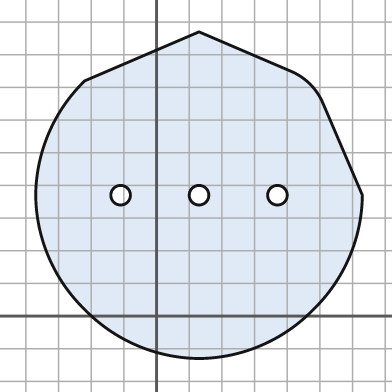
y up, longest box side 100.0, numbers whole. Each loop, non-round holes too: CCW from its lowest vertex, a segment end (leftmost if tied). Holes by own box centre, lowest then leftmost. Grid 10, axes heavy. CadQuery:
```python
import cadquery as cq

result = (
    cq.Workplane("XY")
    .moveTo(13.0, -13.0)
    .threePointArc((32.0, -9.0), (48.0, 2.0))
    .threePointArc((59.0, 18.0), (63.0, 37.0))
    .lineTo(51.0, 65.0)
    .threePointArc((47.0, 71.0), (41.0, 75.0))
    .lineTo(13.0, 87.0)
    .lineTo(-22.0, 72.0)
    .threePointArc((-33.0, 56.0), (-37.0, 37.0))
    .threePointArc((-33.0, 18.0), (-22.0, 2.0))
    .threePointArc((-6.0, -9.0), (13.0, -13.0))
    .close()
    .moveTo(-11.0, 37.0)
    .circle(3.0)
    .moveTo(13.0, 37.0)
    .circle(3.0)
    .moveTo(37.0, 37.0)
    .circle(3.0)
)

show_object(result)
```